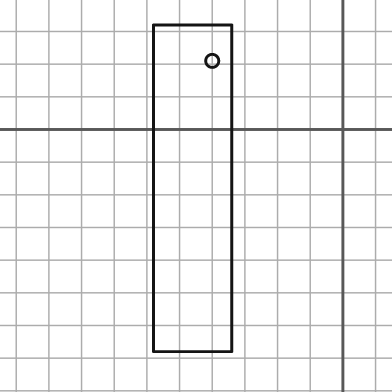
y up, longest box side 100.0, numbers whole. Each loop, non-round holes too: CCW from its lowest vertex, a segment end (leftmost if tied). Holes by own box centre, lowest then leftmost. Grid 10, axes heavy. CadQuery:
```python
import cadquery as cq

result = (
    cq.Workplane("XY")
    .moveTo(-58.0, -68.0)
    .lineTo(-34.0, -68.0)
    .lineTo(-34.0, 32.0)
    .lineTo(-58.0, 32.0)
    .close()
    .moveTo(-40.0, 21.0)
    .circle(2.0)
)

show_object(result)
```